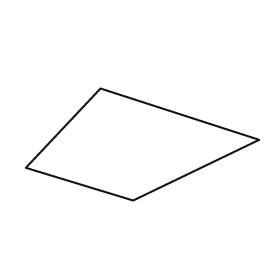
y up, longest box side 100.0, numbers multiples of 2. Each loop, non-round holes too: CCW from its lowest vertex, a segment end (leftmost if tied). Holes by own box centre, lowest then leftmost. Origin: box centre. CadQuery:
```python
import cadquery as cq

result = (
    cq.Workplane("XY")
    .moveTo(-4.0, -24.0)
    .lineTo(50.0, 2.0)
    .lineTo(-18.0, 24.0)
    .lineTo(-50.0, -10.0)
    .close()
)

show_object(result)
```